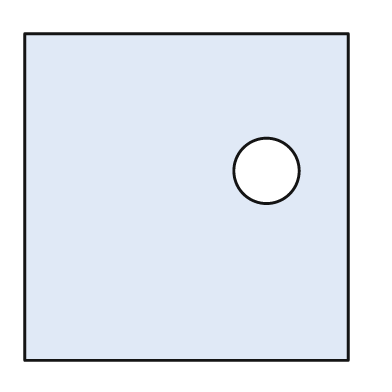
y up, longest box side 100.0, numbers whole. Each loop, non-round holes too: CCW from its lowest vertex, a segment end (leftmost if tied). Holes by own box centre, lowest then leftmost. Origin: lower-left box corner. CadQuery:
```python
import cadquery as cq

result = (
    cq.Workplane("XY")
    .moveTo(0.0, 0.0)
    .lineTo(99.0, 0.0)
    .lineTo(99.0, 100.0)
    .lineTo(0.0, 100.0)
    .close()
    .moveTo(74.0, 58.0)
    .circle(10.0)
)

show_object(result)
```